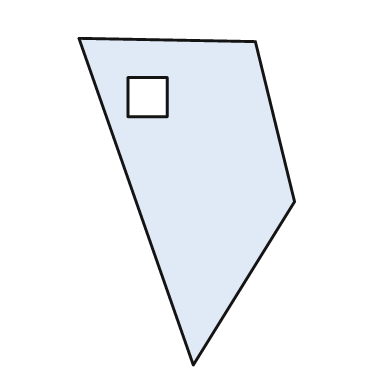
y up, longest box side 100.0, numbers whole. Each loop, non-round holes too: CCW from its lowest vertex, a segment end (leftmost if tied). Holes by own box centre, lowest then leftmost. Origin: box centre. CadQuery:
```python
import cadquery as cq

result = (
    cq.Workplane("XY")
    .moveTo(2.0, -50.0)
    .lineTo(33.0, 0.0)
    .lineTo(21.0, 49.0)
    .lineTo(-33.0, 50.0)
    .close()
    .moveTo(-18.0, 26.0)
    .lineTo(-6.0, 26.0)
    .lineTo(-6.0, 38.0)
    .lineTo(-18.0, 38.0)
    .close()
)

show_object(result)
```